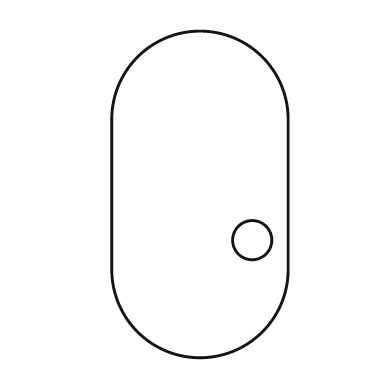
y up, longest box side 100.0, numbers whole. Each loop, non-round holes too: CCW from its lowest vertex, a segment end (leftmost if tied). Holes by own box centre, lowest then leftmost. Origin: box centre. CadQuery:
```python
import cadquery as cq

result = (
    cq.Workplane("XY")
    .moveTo(-27.0, -23.0)
    .threePointArc((0.0, -50.0), (27.0, -23.0))
    .lineTo(27.0, 23.0)
    .threePointArc((0.0, 50.0), (-27.0, 23.0))
    .close()
    .moveTo(16.0, -14.0)
    .circle(6.0)
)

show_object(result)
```